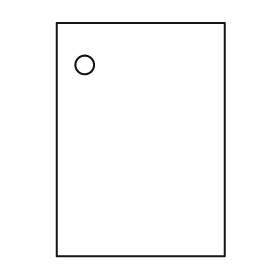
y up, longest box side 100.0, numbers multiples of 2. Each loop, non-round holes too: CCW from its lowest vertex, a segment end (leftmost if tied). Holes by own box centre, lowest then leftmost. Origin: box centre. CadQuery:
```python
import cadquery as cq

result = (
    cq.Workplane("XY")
    .moveTo(-36.0, -50.0)
    .lineTo(36.0, -50.0)
    .lineTo(36.0, 50.0)
    .lineTo(-36.0, 50.0)
    .close()
    .moveTo(-24.0, 32.0)
    .circle(4.0)
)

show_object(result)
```